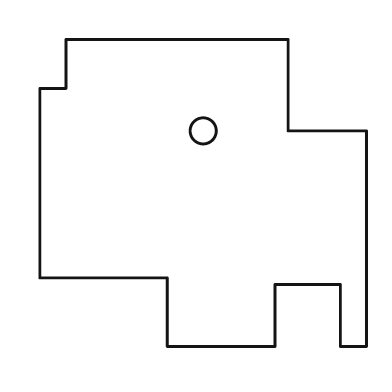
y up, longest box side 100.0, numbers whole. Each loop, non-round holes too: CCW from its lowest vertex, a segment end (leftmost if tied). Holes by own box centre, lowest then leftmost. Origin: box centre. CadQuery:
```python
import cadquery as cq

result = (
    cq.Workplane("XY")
    .moveTo(-11.0, -47.0)
    .lineTo(22.0, -47.0)
    .lineTo(22.0, -28.0)
    .lineTo(42.0, -28.0)
    .lineTo(42.0, -47.0)
    .lineTo(50.0, -47.0)
    .lineTo(50.0, 19.0)
    .lineTo(26.0, 19.0)
    .lineTo(26.0, 47.0)
    .lineTo(-42.0, 47.0)
    .lineTo(-42.0, 32.0)
    .lineTo(-50.0, 32.0)
    .lineTo(-50.0, -26.0)
    .lineTo(-11.0, -26.0)
    .close()
    .moveTo(0.0, 19.0)
    .circle(4.0)
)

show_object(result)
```